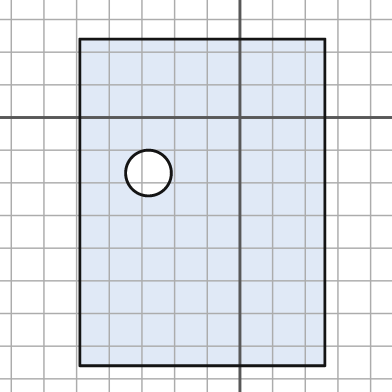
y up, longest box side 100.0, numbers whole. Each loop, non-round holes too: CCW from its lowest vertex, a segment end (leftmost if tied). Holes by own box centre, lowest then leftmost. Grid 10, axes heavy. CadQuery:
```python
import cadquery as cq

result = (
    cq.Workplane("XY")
    .moveTo(-49.0, -76.0)
    .lineTo(26.0, -76.0)
    .lineTo(26.0, 24.0)
    .lineTo(-49.0, 24.0)
    .close()
    .moveTo(-28.0, -17.0)
    .circle(7.0)
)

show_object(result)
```